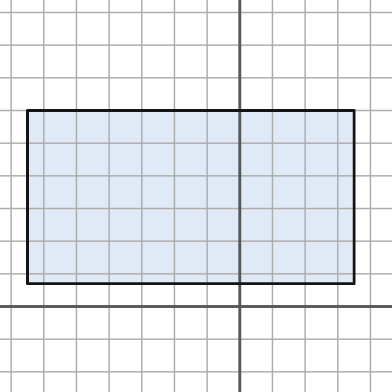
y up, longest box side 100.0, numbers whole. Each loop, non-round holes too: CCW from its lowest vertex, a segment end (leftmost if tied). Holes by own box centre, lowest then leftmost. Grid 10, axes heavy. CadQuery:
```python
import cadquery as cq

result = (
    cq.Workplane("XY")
    .moveTo(-65.0, 7.0)
    .lineTo(35.0, 7.0)
    .lineTo(35.0, 60.0)
    .lineTo(-65.0, 60.0)
    .close()
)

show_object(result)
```